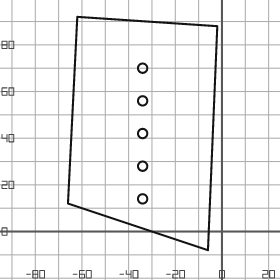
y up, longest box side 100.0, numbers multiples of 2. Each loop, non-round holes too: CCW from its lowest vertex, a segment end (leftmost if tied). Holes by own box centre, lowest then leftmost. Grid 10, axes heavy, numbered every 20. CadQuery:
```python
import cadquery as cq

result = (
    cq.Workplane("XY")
    .moveTo(-6.0, -8.0)
    .lineTo(-2.0, 88.0)
    .lineTo(-62.0, 92.0)
    .lineTo(-66.0, 12.0)
    .close()
    .moveTo(-34.0, 14.0)
    .circle(2.0)
    .moveTo(-34.0, 28.0)
    .circle(2.0)
    .moveTo(-34.0, 42.0)
    .circle(2.0)
    .moveTo(-34.0, 56.0)
    .circle(2.0)
    .moveTo(-34.0, 70.0)
    .circle(2.0)
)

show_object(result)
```